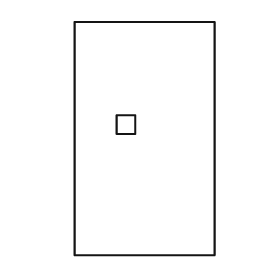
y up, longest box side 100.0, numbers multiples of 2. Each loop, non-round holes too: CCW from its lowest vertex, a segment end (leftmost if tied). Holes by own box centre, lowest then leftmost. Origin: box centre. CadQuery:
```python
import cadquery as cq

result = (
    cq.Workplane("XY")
    .moveTo(-30.0, -50.0)
    .lineTo(30.0, -50.0)
    .lineTo(30.0, 50.0)
    .lineTo(-30.0, 50.0)
    .close()
    .moveTo(-12.0, 2.0)
    .lineTo(-4.0, 2.0)
    .lineTo(-4.0, 10.0)
    .lineTo(-12.0, 10.0)
    .close()
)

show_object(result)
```